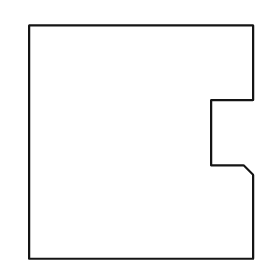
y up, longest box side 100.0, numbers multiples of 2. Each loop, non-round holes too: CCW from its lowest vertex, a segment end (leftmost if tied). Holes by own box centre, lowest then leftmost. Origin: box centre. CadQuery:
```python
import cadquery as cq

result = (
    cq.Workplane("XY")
    .moveTo(-48.0, -50.0)
    .lineTo(48.0, -50.0)
    .lineTo(48.0, -14.0)
    .lineTo(44.0, -10.0)
    .lineTo(30.0, -10.0)
    .lineTo(30.0, 18.0)
    .lineTo(48.0, 18.0)
    .lineTo(48.0, 50.0)
    .lineTo(-48.0, 50.0)
    .close()
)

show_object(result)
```